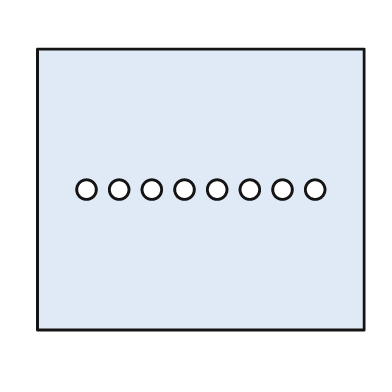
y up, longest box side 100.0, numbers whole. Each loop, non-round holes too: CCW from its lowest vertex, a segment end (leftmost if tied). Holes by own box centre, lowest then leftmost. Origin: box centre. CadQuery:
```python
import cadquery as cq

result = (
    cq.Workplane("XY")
    .moveTo(-50.0, -43.0)
    .lineTo(50.0, -43.0)
    .lineTo(50.0, 43.0)
    .lineTo(-50.0, 43.0)
    .close()
    .moveTo(-35.0, 0.0)
    .circle(3.0)
    .moveTo(-25.0, 0.0)
    .circle(3.0)
    .moveTo(-15.0, 0.0)
    .circle(3.0)
    .moveTo(-5.0, 0.0)
    .circle(3.0)
    .moveTo(5.0, 0.0)
    .circle(3.0)
    .moveTo(15.0, 0.0)
    .circle(3.0)
    .moveTo(25.0, 0.0)
    .circle(3.0)
    .moveTo(35.0, 0.0)
    .circle(3.0)
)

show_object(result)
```